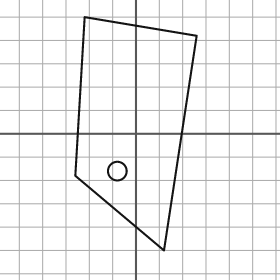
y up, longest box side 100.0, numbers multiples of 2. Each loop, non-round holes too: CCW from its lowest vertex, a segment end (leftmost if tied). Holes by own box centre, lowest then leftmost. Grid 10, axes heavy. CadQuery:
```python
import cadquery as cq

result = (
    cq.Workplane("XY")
    .moveTo(12.0, -50.0)
    .lineTo(26.0, 42.0)
    .lineTo(-22.0, 50.0)
    .lineTo(-26.0, -18.0)
    .close()
    .moveTo(-8.0, -16.0)
    .circle(4.0)
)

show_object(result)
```